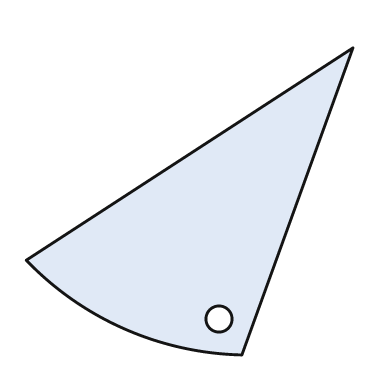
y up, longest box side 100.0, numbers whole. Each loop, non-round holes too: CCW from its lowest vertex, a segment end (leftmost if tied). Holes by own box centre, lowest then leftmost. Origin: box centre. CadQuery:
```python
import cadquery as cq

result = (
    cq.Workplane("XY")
    .moveTo(16.0, -47.0)
    .lineTo(50.0, 47.0)
    .lineTo(-50.0, -18.0)
    .threePointArc((-20.0, -39.0), (16.0, -47.0))
    .close()
    .moveTo(9.0, -36.0)
    .circle(4.0)
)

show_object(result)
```